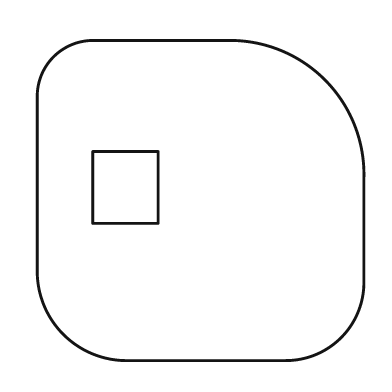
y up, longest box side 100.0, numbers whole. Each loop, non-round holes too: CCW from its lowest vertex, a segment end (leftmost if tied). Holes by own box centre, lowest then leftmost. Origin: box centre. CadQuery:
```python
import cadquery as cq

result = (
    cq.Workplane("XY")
    .moveTo(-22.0, -49.0)
    .lineTo(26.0, -49.0)
    .threePointArc((43.0, -42.0), (50.0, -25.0))
    .lineTo(50.0, 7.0)
    .threePointArc((38.0, 37.0), (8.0, 49.0))
    .lineTo(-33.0, 49.0)
    .threePointArc((-45.0, 44.0), (-50.0, 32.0))
    .lineTo(-50.0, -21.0)
    .threePointArc((-42.0, -41.0), (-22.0, -49.0))
    .close()
    .moveTo(-33.0, -7.0)
    .lineTo(-13.0, -7.0)
    .lineTo(-13.0, 15.0)
    .lineTo(-33.0, 15.0)
    .close()
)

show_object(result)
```